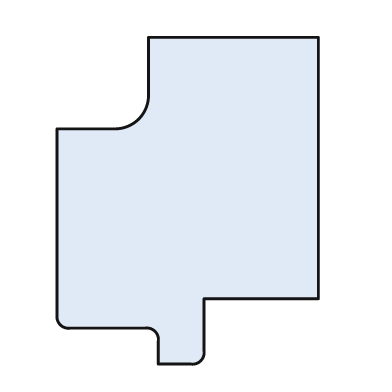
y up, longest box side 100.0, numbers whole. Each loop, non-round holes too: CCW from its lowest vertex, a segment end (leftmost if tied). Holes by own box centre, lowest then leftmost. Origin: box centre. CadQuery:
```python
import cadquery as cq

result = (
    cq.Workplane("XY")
    .moveTo(-9.0, -50.0)
    .lineTo(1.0, -50.0)
    .threePointArc((4.0, -49.0), (5.0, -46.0))
    .lineTo(5.0, -30.0)
    .lineTo(40.0, -30.0)
    .lineTo(40.0, 50.0)
    .lineTo(-12.0, 50.0)
    .lineTo(-12.0, 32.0)
    .threePointArc((-15.0, 25.0), (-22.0, 22.0))
    .lineTo(-40.0, 22.0)
    .lineTo(-40.0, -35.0)
    .threePointArc((-39.0, -38.0), (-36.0, -39.0))
    .lineTo(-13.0, -39.0)
    .threePointArc((-10.0, -40.0), (-9.0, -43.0))
    .close()
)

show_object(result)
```